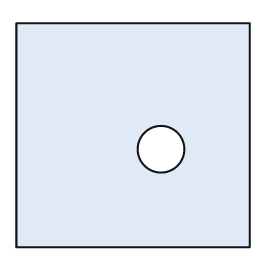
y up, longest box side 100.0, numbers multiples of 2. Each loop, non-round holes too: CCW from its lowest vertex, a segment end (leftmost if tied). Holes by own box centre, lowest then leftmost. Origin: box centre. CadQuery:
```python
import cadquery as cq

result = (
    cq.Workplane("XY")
    .moveTo(-50.0, -48.0)
    .lineTo(50.0, -48.0)
    .lineTo(50.0, 48.0)
    .lineTo(-50.0, 48.0)
    .close()
    .moveTo(12.0, -6.0)
    .circle(10.0)
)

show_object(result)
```